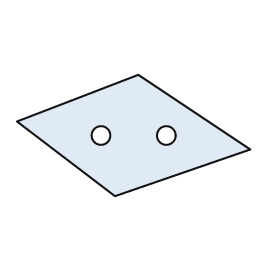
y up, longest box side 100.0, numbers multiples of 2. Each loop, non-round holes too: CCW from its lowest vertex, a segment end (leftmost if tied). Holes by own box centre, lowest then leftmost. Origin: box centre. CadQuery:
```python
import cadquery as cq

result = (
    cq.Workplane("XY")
    .moveTo(-8.0, -26.0)
    .lineTo(50.0, -6.0)
    .lineTo(2.0, 26.0)
    .lineTo(-50.0, 6.0)
    .close()
    .moveTo(-14.0, 0.0)
    .circle(4.0)
    .moveTo(14.0, 0.0)
    .circle(4.0)
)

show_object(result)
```